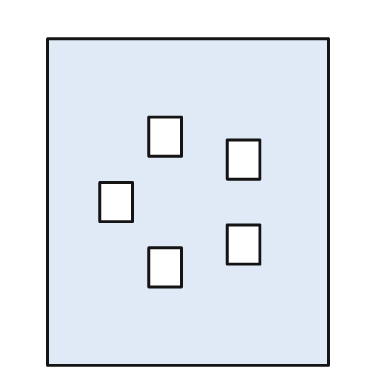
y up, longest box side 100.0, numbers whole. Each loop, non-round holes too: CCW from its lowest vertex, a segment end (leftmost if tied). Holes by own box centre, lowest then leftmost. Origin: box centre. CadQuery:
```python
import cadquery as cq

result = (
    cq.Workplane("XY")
    .moveTo(-43.0, -50.0)
    .lineTo(43.0, -50.0)
    .lineTo(43.0, 50.0)
    .lineTo(-43.0, 50.0)
    .close()
    .moveTo(-12.0, -26.0)
    .lineTo(-2.0, -26.0)
    .lineTo(-2.0, -14.0)
    .lineTo(-12.0, -14.0)
    .close()
    .moveTo(12.0, -19.0)
    .lineTo(22.0, -19.0)
    .lineTo(22.0, -7.0)
    .lineTo(12.0, -7.0)
    .close()
    .moveTo(-27.0, -6.0)
    .lineTo(-17.0, -6.0)
    .lineTo(-17.0, 6.0)
    .lineTo(-27.0, 6.0)
    .close()
    .moveTo(12.0, 7.0)
    .lineTo(22.0, 7.0)
    .lineTo(22.0, 19.0)
    .lineTo(12.0, 19.0)
    .close()
    .moveTo(-12.0, 14.0)
    .lineTo(-2.0, 14.0)
    .lineTo(-2.0, 26.0)
    .lineTo(-12.0, 26.0)
    .close()
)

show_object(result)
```